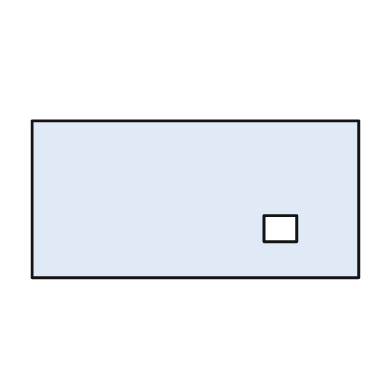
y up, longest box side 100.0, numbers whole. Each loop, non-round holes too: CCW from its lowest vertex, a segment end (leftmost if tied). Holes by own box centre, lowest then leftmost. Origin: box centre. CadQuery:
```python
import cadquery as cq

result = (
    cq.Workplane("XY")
    .moveTo(-50.0, -24.0)
    .lineTo(50.0, -24.0)
    .lineTo(50.0, 24.0)
    .lineTo(-50.0, 24.0)
    .close()
    .moveTo(21.0, -13.0)
    .lineTo(31.0, -13.0)
    .lineTo(31.0, -5.0)
    .lineTo(21.0, -5.0)
    .close()
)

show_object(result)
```